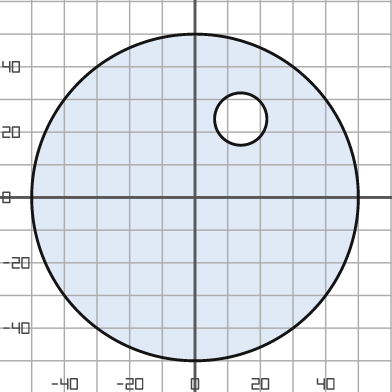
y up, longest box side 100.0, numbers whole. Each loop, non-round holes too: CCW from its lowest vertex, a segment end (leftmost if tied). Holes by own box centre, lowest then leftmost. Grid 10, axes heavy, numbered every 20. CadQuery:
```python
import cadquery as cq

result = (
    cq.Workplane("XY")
    .moveTo(0.0, 0.0)
    .circle(50.0)
    .moveTo(14.0, 24.0)
    .circle(8.0)
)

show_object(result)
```